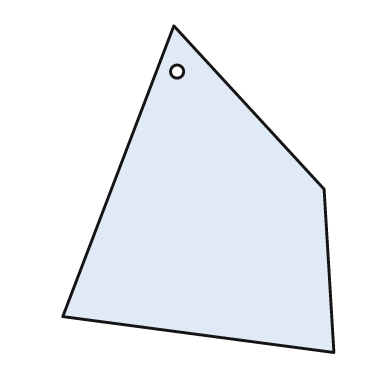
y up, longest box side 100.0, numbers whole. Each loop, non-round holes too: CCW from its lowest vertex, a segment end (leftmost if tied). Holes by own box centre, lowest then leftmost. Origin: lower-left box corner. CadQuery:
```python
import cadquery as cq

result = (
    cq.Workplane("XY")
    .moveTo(83.0, 0.0)
    .lineTo(80.0, 50.0)
    .lineTo(34.0, 100.0)
    .lineTo(0.0, 11.0)
    .close()
    .moveTo(35.0, 86.0)
    .circle(2.0)
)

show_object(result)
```